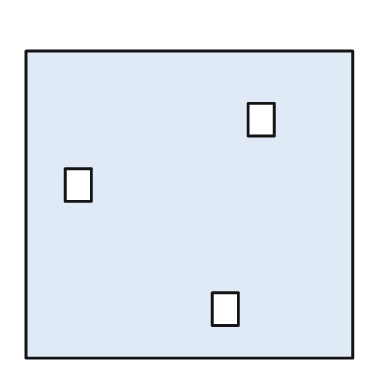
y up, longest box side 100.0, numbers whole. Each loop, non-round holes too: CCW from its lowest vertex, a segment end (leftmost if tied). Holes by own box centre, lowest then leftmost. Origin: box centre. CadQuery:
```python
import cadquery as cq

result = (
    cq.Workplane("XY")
    .moveTo(-50.0, -47.0)
    .lineTo(50.0, -47.0)
    .lineTo(50.0, 47.0)
    .lineTo(-50.0, 47.0)
    .close()
    .moveTo(7.0, -37.0)
    .lineTo(15.0, -37.0)
    .lineTo(15.0, -27.0)
    .lineTo(7.0, -27.0)
    .close()
    .moveTo(-38.0, 1.0)
    .lineTo(-30.0, 1.0)
    .lineTo(-30.0, 11.0)
    .lineTo(-38.0, 11.0)
    .close()
    .moveTo(18.0, 21.0)
    .lineTo(26.0, 21.0)
    .lineTo(26.0, 31.0)
    .lineTo(18.0, 31.0)
    .close()
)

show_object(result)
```